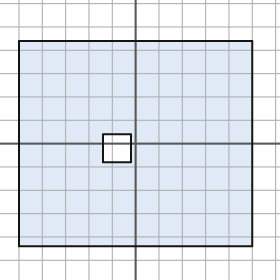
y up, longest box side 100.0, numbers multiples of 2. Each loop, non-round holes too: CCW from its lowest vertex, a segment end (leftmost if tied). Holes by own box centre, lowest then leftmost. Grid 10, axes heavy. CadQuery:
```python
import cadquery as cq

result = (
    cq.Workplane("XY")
    .moveTo(-50.0, -44.0)
    .lineTo(50.0, -44.0)
    .lineTo(50.0, 44.0)
    .lineTo(-50.0, 44.0)
    .close()
    .moveTo(-14.0, -8.0)
    .lineTo(-2.0, -8.0)
    .lineTo(-2.0, 4.0)
    .lineTo(-14.0, 4.0)
    .close()
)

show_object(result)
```